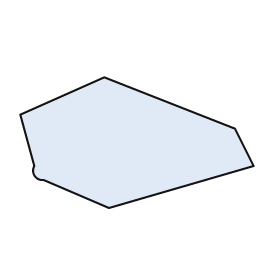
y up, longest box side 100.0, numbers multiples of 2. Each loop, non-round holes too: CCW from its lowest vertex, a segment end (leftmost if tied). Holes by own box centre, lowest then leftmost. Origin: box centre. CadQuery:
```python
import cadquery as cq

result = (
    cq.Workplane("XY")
    .moveTo(-12.0, -28.0)
    .lineTo(50.0, -10.0)
    .lineTo(42.0, 6.0)
    .lineTo(-14.0, 28.0)
    .lineTo(-50.0, 12.0)
    .lineTo(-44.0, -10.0)
    .threePointArc((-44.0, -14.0), (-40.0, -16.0))
    .close()
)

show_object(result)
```